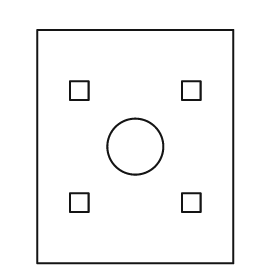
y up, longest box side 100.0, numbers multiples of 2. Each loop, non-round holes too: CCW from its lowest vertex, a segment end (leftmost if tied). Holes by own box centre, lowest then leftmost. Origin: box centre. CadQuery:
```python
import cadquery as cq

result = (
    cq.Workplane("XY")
    .moveTo(-42.0, -50.0)
    .lineTo(42.0, -50.0)
    .lineTo(42.0, 50.0)
    .lineTo(-42.0, 50.0)
    .close()
    .moveTo(-28.0, -28.0)
    .lineTo(-20.0, -28.0)
    .lineTo(-20.0, -20.0)
    .lineTo(-28.0, -20.0)
    .close()
    .moveTo(20.0, -28.0)
    .lineTo(28.0, -28.0)
    .lineTo(28.0, -20.0)
    .lineTo(20.0, -20.0)
    .close()
    .moveTo(0.0, 0.0)
    .circle(12.0)
    .moveTo(-28.0, 20.0)
    .lineTo(-20.0, 20.0)
    .lineTo(-20.0, 28.0)
    .lineTo(-28.0, 28.0)
    .close()
    .moveTo(20.0, 20.0)
    .lineTo(28.0, 20.0)
    .lineTo(28.0, 28.0)
    .lineTo(20.0, 28.0)
    .close()
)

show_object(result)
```